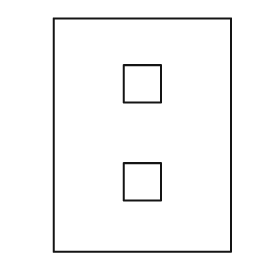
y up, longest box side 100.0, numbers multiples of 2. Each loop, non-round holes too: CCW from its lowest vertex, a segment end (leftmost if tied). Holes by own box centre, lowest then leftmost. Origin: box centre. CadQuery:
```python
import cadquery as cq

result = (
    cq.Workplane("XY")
    .moveTo(-38.0, -50.0)
    .lineTo(38.0, -50.0)
    .lineTo(38.0, 50.0)
    .lineTo(-38.0, 50.0)
    .close()
    .moveTo(-8.0, -28.0)
    .lineTo(8.0, -28.0)
    .lineTo(8.0, -12.0)
    .lineTo(-8.0, -12.0)
    .close()
    .moveTo(-8.0, 14.0)
    .lineTo(8.0, 14.0)
    .lineTo(8.0, 30.0)
    .lineTo(-8.0, 30.0)
    .close()
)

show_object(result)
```